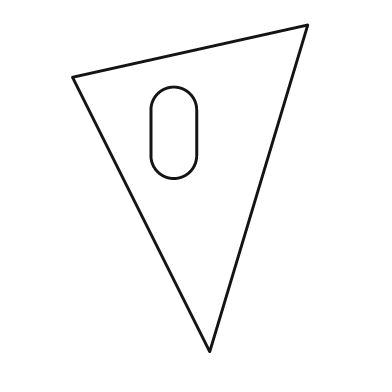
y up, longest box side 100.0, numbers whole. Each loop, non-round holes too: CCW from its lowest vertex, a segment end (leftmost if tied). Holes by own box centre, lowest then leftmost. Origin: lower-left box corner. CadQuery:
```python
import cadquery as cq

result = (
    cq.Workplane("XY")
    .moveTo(42.0, 0.0)
    .lineTo(72.0, 100.0)
    .lineTo(0.0, 84.0)
    .close()
    .moveTo(24.0, 60.0)
    .threePointArc((31.0, 53.0), (38.0, 60.0))
    .lineTo(38.0, 74.0)
    .threePointArc((31.0, 81.0), (24.0, 74.0))
    .close()
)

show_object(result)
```